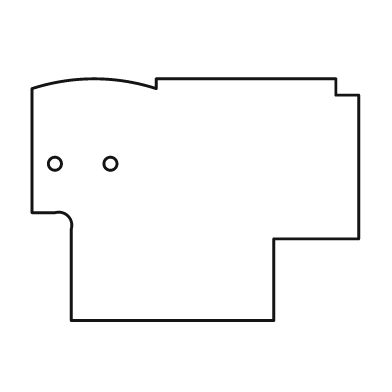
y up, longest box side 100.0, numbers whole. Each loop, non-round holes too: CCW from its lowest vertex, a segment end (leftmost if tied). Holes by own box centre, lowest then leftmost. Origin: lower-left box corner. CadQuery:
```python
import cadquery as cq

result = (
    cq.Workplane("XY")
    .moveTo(12.0, 0.0)
    .lineTo(74.0, 0.0)
    .lineTo(74.0, 25.0)
    .lineTo(100.0, 25.0)
    .lineTo(100.0, 69.0)
    .lineTo(93.0, 69.0)
    .lineTo(93.0, 74.0)
    .lineTo(38.0, 74.0)
    .lineTo(38.0, 71.0)
    .threePointArc((19.0, 74.0), (0.0, 71.0))
    .lineTo(0.0, 33.0)
    .lineTo(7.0, 33.0)
    .threePointArc((11.0, 32.0), (12.0, 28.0))
    .close()
    .moveTo(7.0, 48.0)
    .circle(2.0)
    .moveTo(24.0, 48.0)
    .circle(2.0)
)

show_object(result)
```